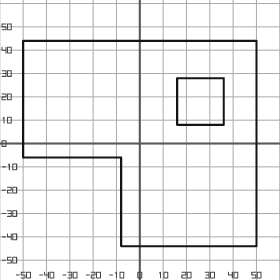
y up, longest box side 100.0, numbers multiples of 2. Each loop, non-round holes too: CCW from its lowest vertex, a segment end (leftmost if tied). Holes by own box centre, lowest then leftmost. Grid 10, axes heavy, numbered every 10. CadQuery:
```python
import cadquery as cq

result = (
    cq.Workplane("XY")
    .moveTo(-8.0, -44.0)
    .lineTo(50.0, -44.0)
    .lineTo(50.0, 44.0)
    .lineTo(-50.0, 44.0)
    .lineTo(-50.0, -6.0)
    .lineTo(-8.0, -6.0)
    .close()
    .moveTo(16.0, 8.0)
    .lineTo(36.0, 8.0)
    .lineTo(36.0, 28.0)
    .lineTo(16.0, 28.0)
    .close()
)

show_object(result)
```